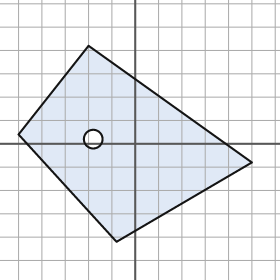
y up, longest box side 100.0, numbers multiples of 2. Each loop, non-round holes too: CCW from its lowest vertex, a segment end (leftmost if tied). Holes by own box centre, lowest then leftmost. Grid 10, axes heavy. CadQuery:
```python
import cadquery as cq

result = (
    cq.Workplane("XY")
    .moveTo(-8.0, -42.0)
    .lineTo(50.0, -8.0)
    .lineTo(-20.0, 42.0)
    .lineTo(-50.0, 4.0)
    .close()
    .moveTo(-18.0, 2.0)
    .circle(4.0)
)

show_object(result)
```